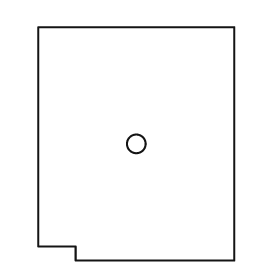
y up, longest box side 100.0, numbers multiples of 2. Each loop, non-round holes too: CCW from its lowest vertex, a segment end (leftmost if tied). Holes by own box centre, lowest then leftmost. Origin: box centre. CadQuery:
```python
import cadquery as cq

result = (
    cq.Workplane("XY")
    .moveTo(-26.0, -50.0)
    .lineTo(42.0, -50.0)
    .lineTo(42.0, 50.0)
    .lineTo(-42.0, 50.0)
    .lineTo(-42.0, -44.0)
    .lineTo(-26.0, -44.0)
    .close()
    .moveTo(0.0, 0.0)
    .circle(4.0)
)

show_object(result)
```